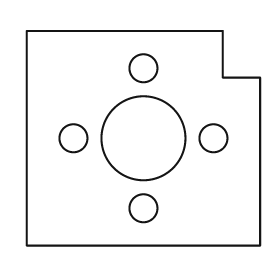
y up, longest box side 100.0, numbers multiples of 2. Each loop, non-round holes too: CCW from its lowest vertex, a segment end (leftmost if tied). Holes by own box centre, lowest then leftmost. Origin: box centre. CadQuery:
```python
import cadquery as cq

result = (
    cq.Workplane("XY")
    .moveTo(-50.0, -46.0)
    .lineTo(50.0, -46.0)
    .lineTo(50.0, 26.0)
    .lineTo(34.0, 26.0)
    .lineTo(34.0, 46.0)
    .lineTo(-50.0, 46.0)
    .close()
    .moveTo(0.0, -30.0)
    .circle(6.0)
    .moveTo(-30.0, 0.0)
    .circle(6.0)
    .moveTo(0.0, 0.0)
    .circle(18.0)
    .moveTo(30.0, 0.0)
    .circle(6.0)
    .moveTo(0.0, 30.0)
    .circle(6.0)
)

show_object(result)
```